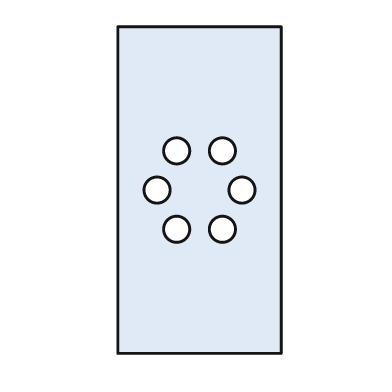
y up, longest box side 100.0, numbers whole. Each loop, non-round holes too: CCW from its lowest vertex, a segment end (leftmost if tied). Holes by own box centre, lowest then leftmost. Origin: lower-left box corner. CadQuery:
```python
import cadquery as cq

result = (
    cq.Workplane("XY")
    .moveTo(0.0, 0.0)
    .lineTo(50.0, 0.0)
    .lineTo(50.0, 100.0)
    .lineTo(0.0, 100.0)
    .close()
    .moveTo(18.0, 38.0)
    .circle(4.0)
    .moveTo(32.0, 38.0)
    .circle(4.0)
    .moveTo(12.0, 50.0)
    .circle(4.0)
    .moveTo(38.0, 50.0)
    .circle(4.0)
    .moveTo(18.0, 62.0)
    .circle(4.0)
    .moveTo(32.0, 62.0)
    .circle(4.0)
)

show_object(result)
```